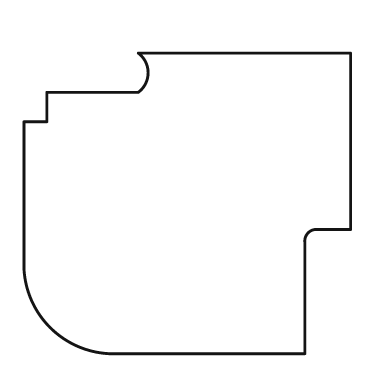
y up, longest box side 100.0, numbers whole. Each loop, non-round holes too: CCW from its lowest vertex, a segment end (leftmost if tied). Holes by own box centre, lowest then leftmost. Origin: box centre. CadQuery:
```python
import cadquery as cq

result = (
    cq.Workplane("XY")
    .moveTo(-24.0, -46.0)
    .lineTo(36.0, -46.0)
    .lineTo(36.0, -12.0)
    .threePointArc((37.0, -9.0), (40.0, -8.0))
    .lineTo(50.0, -8.0)
    .lineTo(50.0, 46.0)
    .lineTo(-15.0, 46.0)
    .threePointArc((-12.0, 40.0), (-15.0, 34.0))
    .lineTo(-43.0, 34.0)
    .lineTo(-43.0, 25.0)
    .lineTo(-50.0, 25.0)
    .lineTo(-50.0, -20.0)
    .threePointArc((-42.0, -38.0), (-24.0, -46.0))
    .close()
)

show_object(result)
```